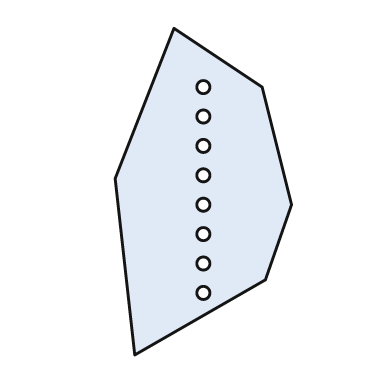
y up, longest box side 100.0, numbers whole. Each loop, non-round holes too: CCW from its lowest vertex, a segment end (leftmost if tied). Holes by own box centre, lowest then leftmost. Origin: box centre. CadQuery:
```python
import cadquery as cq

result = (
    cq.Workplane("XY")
    .moveTo(-21.0, -50.0)
    .lineTo(19.0, -27.0)
    .lineTo(27.0, -4.0)
    .lineTo(18.0, 32.0)
    .lineTo(-9.0, 50.0)
    .lineTo(-27.0, 4.0)
    .close()
    .moveTo(0.0, -31.0)
    .circle(2.0)
    .moveTo(0.0, -22.0)
    .circle(2.0)
    .moveTo(0.0, -13.0)
    .circle(2.0)
    .moveTo(0.0, -4.0)
    .circle(2.0)
    .moveTo(0.0, 5.0)
    .circle(2.0)
    .moveTo(0.0, 14.0)
    .circle(2.0)
    .moveTo(0.0, 23.0)
    .circle(2.0)
    .moveTo(0.0, 32.0)
    .circle(2.0)
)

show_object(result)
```